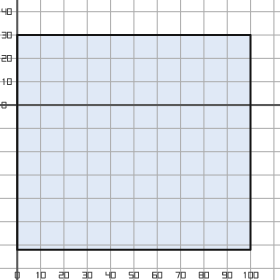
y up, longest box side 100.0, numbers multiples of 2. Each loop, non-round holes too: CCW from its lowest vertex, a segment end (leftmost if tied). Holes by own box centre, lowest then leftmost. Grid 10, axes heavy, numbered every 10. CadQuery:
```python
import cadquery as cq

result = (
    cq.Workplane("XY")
    .moveTo(0.0, -62.0)
    .lineTo(100.0, -62.0)
    .lineTo(100.0, 30.0)
    .lineTo(0.0, 30.0)
    .close()
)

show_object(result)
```